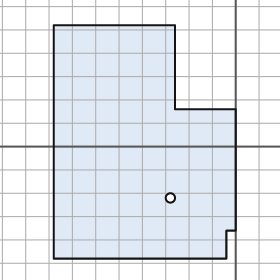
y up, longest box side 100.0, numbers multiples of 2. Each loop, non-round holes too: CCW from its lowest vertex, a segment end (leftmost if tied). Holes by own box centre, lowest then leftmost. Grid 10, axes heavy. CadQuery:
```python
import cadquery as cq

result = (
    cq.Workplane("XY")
    .moveTo(-78.0, -48.0)
    .lineTo(-4.0, -48.0)
    .lineTo(-4.0, -36.0)
    .lineTo(0.0, -36.0)
    .lineTo(0.0, 16.0)
    .lineTo(-26.0, 16.0)
    .lineTo(-26.0, 52.0)
    .lineTo(-78.0, 52.0)
    .close()
    .moveTo(-28.0, -22.0)
    .circle(2.0)
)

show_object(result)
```